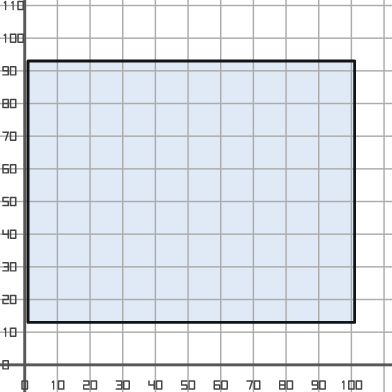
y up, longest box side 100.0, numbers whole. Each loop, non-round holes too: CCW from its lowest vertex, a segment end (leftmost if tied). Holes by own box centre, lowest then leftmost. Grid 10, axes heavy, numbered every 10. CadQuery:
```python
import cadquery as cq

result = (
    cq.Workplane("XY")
    .moveTo(1.0, 13.0)
    .lineTo(101.0, 13.0)
    .lineTo(101.0, 93.0)
    .lineTo(1.0, 93.0)
    .close()
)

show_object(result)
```